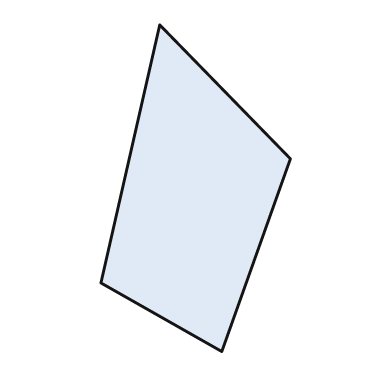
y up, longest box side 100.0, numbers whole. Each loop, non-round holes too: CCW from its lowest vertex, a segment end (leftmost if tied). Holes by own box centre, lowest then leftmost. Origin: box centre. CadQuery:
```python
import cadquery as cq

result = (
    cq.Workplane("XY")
    .moveTo(8.0, -50.0)
    .lineTo(29.0, 9.0)
    .lineTo(-11.0, 50.0)
    .lineTo(-29.0, -29.0)
    .close()
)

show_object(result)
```